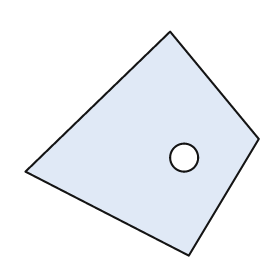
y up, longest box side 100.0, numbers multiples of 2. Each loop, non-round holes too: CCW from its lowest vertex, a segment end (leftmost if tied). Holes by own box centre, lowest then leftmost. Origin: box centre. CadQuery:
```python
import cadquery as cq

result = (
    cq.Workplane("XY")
    .moveTo(20.0, -48.0)
    .lineTo(50.0, 2.0)
    .lineTo(12.0, 48.0)
    .lineTo(-50.0, -12.0)
    .close()
    .moveTo(18.0, -6.0)
    .circle(6.0)
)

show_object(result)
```